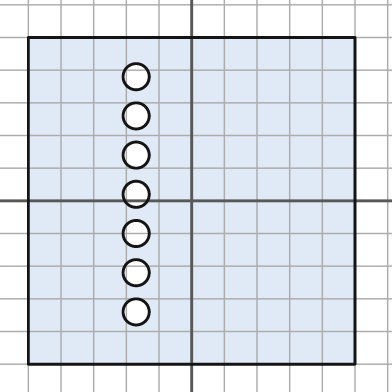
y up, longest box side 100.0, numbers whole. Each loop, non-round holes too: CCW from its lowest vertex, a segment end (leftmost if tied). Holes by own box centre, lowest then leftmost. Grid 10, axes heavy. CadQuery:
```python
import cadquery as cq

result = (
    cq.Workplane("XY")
    .moveTo(-50.0, -50.0)
    .lineTo(50.0, -50.0)
    .lineTo(50.0, 50.0)
    .lineTo(-50.0, 50.0)
    .close()
    .moveTo(-17.0, -34.0)
    .circle(4.0)
    .moveTo(-17.0, -22.0)
    .circle(4.0)
    .moveTo(-17.0, -10.0)
    .circle(4.0)
    .moveTo(-17.0, 2.0)
    .circle(4.0)
    .moveTo(-17.0, 14.0)
    .circle(4.0)
    .moveTo(-17.0, 26.0)
    .circle(4.0)
    .moveTo(-17.0, 38.0)
    .circle(4.0)
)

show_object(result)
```